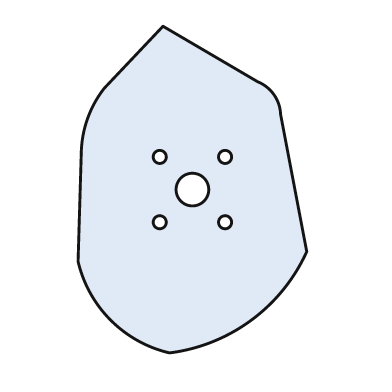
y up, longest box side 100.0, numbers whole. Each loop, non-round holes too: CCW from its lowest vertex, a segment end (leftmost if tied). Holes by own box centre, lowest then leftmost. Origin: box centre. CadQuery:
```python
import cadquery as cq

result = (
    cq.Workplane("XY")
    .moveTo(-7.0, -50.0)
    .threePointArc((18.0, -40.0), (35.0, -19.0))
    .lineTo(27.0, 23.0)
    .threePointArc((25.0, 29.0), (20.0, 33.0))
    .lineTo(-9.0, 50.0)
    .lineTo(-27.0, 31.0)
    .threePointArc((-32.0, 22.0), (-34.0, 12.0))
    .lineTo(-35.0, -22.0)
    .threePointArc((-25.0, -40.0), (-7.0, -50.0))
    .close()
    .moveTo(-10.0, -10.0)
    .circle(2.0)
    .moveTo(10.0, -10.0)
    .circle(2.0)
    .moveTo(0.0, 0.0)
    .circle(5.0)
    .moveTo(-10.0, 10.0)
    .circle(2.0)
    .moveTo(10.0, 10.0)
    .circle(2.0)
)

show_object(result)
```